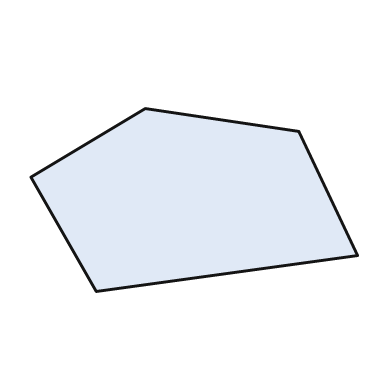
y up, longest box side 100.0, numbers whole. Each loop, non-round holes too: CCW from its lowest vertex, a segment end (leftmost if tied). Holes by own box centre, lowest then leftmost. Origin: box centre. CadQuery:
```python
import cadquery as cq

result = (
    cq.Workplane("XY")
    .moveTo(-30.0, -28.0)
    .lineTo(50.0, -17.0)
    .lineTo(32.0, 21.0)
    .lineTo(-15.0, 28.0)
    .lineTo(-50.0, 7.0)
    .close()
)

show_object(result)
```